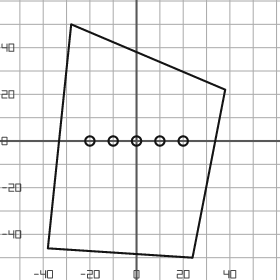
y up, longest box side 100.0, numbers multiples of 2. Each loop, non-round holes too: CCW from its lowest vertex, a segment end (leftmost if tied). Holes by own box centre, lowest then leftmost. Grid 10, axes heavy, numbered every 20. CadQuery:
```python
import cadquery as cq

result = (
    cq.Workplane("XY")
    .moveTo(24.0, -50.0)
    .lineTo(38.0, 22.0)
    .lineTo(-28.0, 50.0)
    .lineTo(-38.0, -46.0)
    .close()
    .moveTo(-20.0, 0.0)
    .circle(2.0)
    .moveTo(-10.0, 0.0)
    .circle(2.0)
    .moveTo(0.0, 0.0)
    .circle(2.0)
    .moveTo(10.0, 0.0)
    .circle(2.0)
    .moveTo(20.0, 0.0)
    .circle(2.0)
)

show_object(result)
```